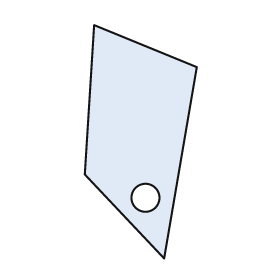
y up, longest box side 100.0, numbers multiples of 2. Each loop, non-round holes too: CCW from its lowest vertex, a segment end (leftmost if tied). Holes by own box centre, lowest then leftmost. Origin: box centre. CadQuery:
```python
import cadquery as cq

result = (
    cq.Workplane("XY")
    .moveTo(10.0, -50.0)
    .lineTo(24.0, 32.0)
    .lineTo(-20.0, 50.0)
    .lineTo(-24.0, -14.0)
    .close()
    .moveTo(2.0, -24.0)
    .circle(6.0)
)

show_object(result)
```